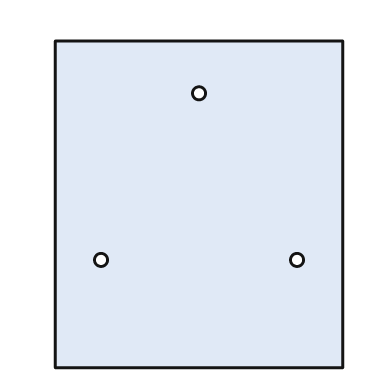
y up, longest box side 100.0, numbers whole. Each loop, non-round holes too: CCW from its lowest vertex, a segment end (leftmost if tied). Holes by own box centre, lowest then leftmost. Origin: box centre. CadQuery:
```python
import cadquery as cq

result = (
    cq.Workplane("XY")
    .moveTo(-44.0, -50.0)
    .lineTo(44.0, -50.0)
    .lineTo(44.0, 50.0)
    .lineTo(-44.0, 50.0)
    .close()
    .moveTo(-30.0, -17.0)
    .circle(2.0)
    .moveTo(30.0, -17.0)
    .circle(2.0)
    .moveTo(0.0, 34.0)
    .circle(2.0)
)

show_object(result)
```